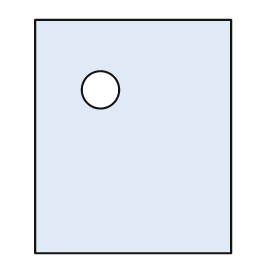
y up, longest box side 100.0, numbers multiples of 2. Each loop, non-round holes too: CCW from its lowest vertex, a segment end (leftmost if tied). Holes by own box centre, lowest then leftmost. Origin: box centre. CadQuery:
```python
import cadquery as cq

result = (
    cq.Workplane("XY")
    .moveTo(-42.0, -50.0)
    .lineTo(42.0, -50.0)
    .lineTo(42.0, 50.0)
    .lineTo(-42.0, 50.0)
    .close()
    .moveTo(-14.0, 20.0)
    .circle(8.0)
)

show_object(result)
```